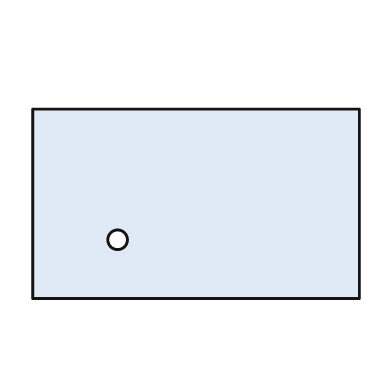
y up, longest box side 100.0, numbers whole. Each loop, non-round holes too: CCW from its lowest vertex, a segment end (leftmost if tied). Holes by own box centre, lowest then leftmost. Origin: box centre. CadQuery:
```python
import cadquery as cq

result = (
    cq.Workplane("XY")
    .moveTo(-50.0, -29.0)
    .lineTo(50.0, -29.0)
    .lineTo(50.0, 29.0)
    .lineTo(-50.0, 29.0)
    .close()
    .moveTo(-24.0, -11.0)
    .circle(3.0)
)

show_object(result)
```